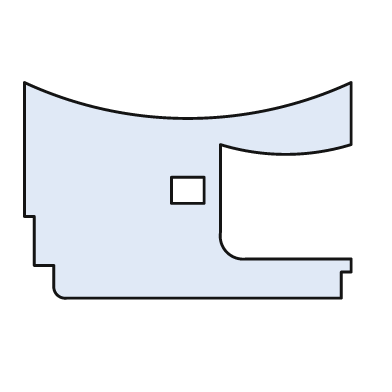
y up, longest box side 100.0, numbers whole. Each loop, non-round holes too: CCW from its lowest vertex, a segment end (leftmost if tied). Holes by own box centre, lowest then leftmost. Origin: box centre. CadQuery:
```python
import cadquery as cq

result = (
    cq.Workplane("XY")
    .moveTo(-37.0, -33.0)
    .lineTo(47.0, -33.0)
    .lineTo(47.0, -25.0)
    .lineTo(50.0, -25.0)
    .lineTo(50.0, -21.0)
    .lineTo(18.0, -21.0)
    .threePointArc((12.0, -19.0), (10.0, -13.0))
    .lineTo(10.0, 14.0)
    .threePointArc((30.0, 11.0), (50.0, 14.0))
    .lineTo(50.0, 33.0)
    .threePointArc((0.0, 22.0), (-50.0, 33.0))
    .lineTo(-50.0, -8.0)
    .lineTo(-47.0, -8.0)
    .lineTo(-47.0, -23.0)
    .lineTo(-41.0, -23.0)
    .lineTo(-41.0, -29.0)
    .threePointArc((-40.0, -32.0), (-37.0, -33.0))
    .close()
    .moveTo(-5.0, -4.0)
    .lineTo(5.0, -4.0)
    .lineTo(5.0, 4.0)
    .lineTo(-5.0, 4.0)
    .close()
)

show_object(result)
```